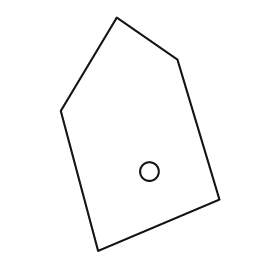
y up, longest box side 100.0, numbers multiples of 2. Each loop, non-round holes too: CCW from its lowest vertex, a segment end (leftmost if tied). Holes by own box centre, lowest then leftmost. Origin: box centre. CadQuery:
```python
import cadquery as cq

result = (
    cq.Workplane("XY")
    .moveTo(-18.0, -50.0)
    .lineTo(34.0, -28.0)
    .lineTo(16.0, 32.0)
    .lineTo(-10.0, 50.0)
    .lineTo(-34.0, 10.0)
    .close()
    .moveTo(4.0, -16.0)
    .circle(4.0)
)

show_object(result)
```